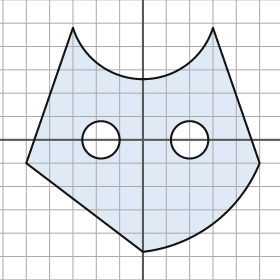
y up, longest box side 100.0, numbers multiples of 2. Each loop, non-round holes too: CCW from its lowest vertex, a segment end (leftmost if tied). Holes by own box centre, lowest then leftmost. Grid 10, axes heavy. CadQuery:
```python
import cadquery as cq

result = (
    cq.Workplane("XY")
    .moveTo(0.0, -48.0)
    .threePointArc((30.0, -36.0), (50.0, -10.0))
    .lineTo(30.0, 48.0)
    .threePointArc((0.0, 26.0), (-30.0, 48.0))
    .lineTo(-50.0, -10.0)
    .close()
    .moveTo(-18.0, 0.0)
    .circle(8.0)
    .moveTo(20.0, 0.0)
    .circle(8.0)
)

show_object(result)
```